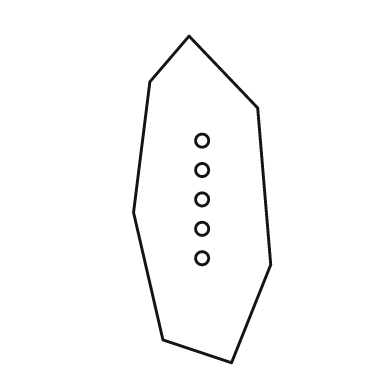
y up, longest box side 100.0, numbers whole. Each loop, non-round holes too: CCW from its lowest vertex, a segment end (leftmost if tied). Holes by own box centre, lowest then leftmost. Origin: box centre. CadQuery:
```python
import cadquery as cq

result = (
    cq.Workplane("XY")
    .moveTo(9.0, -50.0)
    .lineTo(21.0, -20.0)
    .lineTo(17.0, 28.0)
    .lineTo(-4.0, 50.0)
    .lineTo(-16.0, 36.0)
    .lineTo(-21.0, -4.0)
    .lineTo(-12.0, -43.0)
    .close()
    .moveTo(0.0, -18.0)
    .circle(2.0)
    .moveTo(0.0, -9.0)
    .circle(2.0)
    .moveTo(0.0, 0.0)
    .circle(2.0)
    .moveTo(0.0, 9.0)
    .circle(2.0)
    .moveTo(0.0, 18.0)
    .circle(2.0)
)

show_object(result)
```